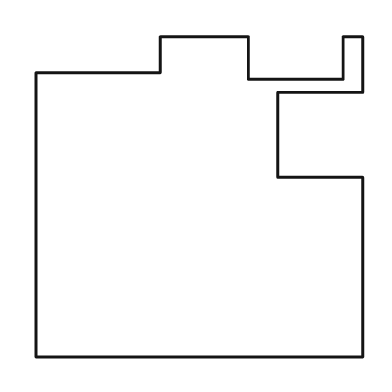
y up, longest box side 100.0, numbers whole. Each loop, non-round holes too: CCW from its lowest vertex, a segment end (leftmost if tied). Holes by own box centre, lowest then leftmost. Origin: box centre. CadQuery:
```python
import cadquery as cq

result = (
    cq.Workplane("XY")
    .moveTo(-50.0, -49.0)
    .lineTo(50.0, -49.0)
    .lineTo(50.0, 6.0)
    .lineTo(24.0, 6.0)
    .lineTo(24.0, 32.0)
    .lineTo(50.0, 32.0)
    .lineTo(50.0, 49.0)
    .lineTo(44.0, 49.0)
    .lineTo(44.0, 36.0)
    .lineTo(15.0, 36.0)
    .lineTo(15.0, 49.0)
    .lineTo(-12.0, 49.0)
    .lineTo(-12.0, 38.0)
    .lineTo(-50.0, 38.0)
    .close()
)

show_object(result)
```